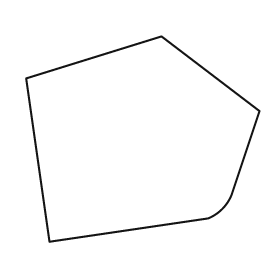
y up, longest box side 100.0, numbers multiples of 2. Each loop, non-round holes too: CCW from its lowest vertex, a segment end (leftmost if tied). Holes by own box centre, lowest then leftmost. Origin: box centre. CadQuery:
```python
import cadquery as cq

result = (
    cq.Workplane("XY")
    .moveTo(-40.0, -44.0)
    .lineTo(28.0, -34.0)
    .threePointArc((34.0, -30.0), (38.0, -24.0))
    .lineTo(50.0, 12.0)
    .lineTo(8.0, 44.0)
    .lineTo(-50.0, 26.0)
    .close()
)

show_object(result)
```